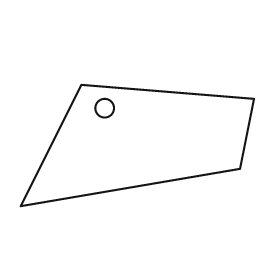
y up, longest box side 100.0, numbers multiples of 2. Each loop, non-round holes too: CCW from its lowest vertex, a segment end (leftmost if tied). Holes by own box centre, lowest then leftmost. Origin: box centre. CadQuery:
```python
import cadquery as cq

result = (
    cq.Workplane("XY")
    .moveTo(-50.0, -26.0)
    .lineTo(44.0, -10.0)
    .lineTo(50.0, 20.0)
    .lineTo(-24.0, 26.0)
    .close()
    .moveTo(-14.0, 16.0)
    .circle(4.0)
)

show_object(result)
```